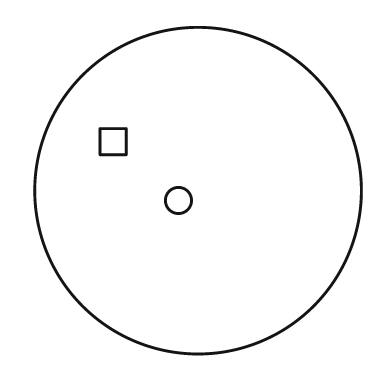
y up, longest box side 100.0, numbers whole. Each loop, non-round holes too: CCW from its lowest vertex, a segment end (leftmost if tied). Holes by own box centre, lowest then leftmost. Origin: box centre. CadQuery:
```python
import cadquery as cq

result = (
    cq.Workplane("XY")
    .moveTo(0.0, 0.0)
    .circle(50.0)
    .moveTo(-6.0, -3.0)
    .circle(4.0)
    .moveTo(-30.0, 11.0)
    .lineTo(-22.0, 11.0)
    .lineTo(-22.0, 19.0)
    .lineTo(-30.0, 19.0)
    .close()
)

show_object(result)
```